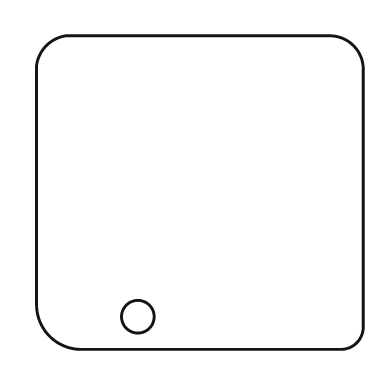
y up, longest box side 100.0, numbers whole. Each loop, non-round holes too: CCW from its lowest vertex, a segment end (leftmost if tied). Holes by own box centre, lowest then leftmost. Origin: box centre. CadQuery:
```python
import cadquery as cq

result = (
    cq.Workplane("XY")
    .moveTo(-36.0, -48.0)
    .lineTo(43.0, -48.0)
    .threePointArc((48.0, -46.0), (50.0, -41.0))
    .lineTo(50.0, 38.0)
    .threePointArc((47.0, 45.0), (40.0, 48.0))
    .lineTo(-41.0, 48.0)
    .threePointArc((-47.0, 45.0), (-50.0, 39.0))
    .lineTo(-50.0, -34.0)
    .threePointArc((-46.0, -44.0), (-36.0, -48.0))
    .close()
    .moveTo(-19.0, -38.0)
    .circle(5.0)
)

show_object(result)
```